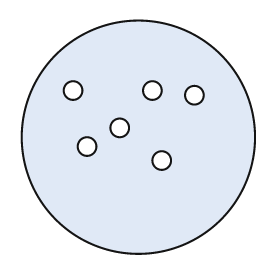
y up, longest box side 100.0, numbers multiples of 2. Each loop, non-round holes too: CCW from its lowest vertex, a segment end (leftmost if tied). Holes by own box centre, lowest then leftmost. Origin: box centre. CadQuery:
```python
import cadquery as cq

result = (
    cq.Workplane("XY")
    .moveTo(0.0, 0.0)
    .circle(50.0)
    .moveTo(10.0, -10.0)
    .circle(4.0)
    .moveTo(-22.0, -4.0)
    .circle(4.0)
    .moveTo(-8.0, 4.0)
    .circle(4.0)
    .moveTo(24.0, 18.0)
    .circle(4.0)
    .moveTo(-28.0, 20.0)
    .circle(4.0)
    .moveTo(6.0, 20.0)
    .circle(4.0)
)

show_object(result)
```